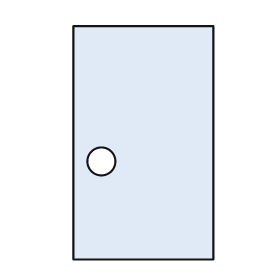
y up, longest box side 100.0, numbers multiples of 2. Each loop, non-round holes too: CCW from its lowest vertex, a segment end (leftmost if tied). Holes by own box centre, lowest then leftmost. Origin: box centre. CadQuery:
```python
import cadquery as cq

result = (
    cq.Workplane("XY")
    .moveTo(-30.0, -50.0)
    .lineTo(30.0, -50.0)
    .lineTo(30.0, 50.0)
    .lineTo(-30.0, 50.0)
    .close()
    .moveTo(-18.0, -8.0)
    .circle(6.0)
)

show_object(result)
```